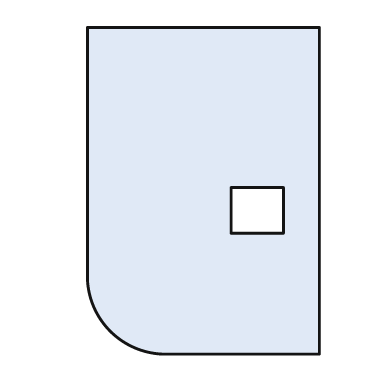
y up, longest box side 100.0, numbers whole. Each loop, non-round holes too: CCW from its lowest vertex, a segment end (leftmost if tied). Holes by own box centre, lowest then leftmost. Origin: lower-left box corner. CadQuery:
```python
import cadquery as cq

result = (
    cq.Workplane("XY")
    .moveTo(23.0, 0.0)
    .lineTo(71.0, 0.0)
    .lineTo(71.0, 100.0)
    .lineTo(0.0, 100.0)
    .lineTo(0.0, 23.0)
    .threePointArc((7.0, 7.0), (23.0, 0.0))
    .close()
    .moveTo(44.0, 37.0)
    .lineTo(60.0, 37.0)
    .lineTo(60.0, 51.0)
    .lineTo(44.0, 51.0)
    .close()
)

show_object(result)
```